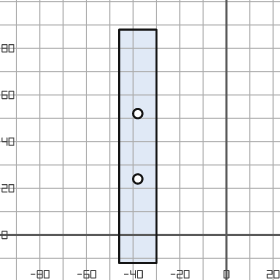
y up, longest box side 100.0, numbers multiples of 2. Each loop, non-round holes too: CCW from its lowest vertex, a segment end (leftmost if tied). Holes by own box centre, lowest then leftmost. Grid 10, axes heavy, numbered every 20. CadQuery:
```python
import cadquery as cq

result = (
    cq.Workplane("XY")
    .moveTo(-46.0, -12.0)
    .lineTo(-30.0, -12.0)
    .lineTo(-30.0, 88.0)
    .lineTo(-46.0, 88.0)
    .close()
    .moveTo(-38.0, 24.0)
    .circle(2.0)
    .moveTo(-38.0, 52.0)
    .circle(2.0)
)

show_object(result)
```